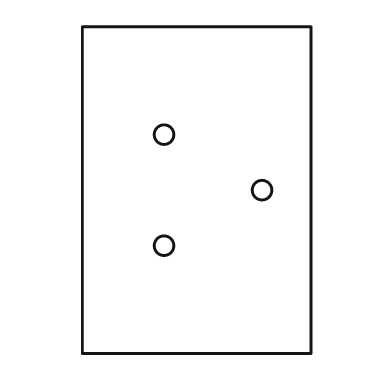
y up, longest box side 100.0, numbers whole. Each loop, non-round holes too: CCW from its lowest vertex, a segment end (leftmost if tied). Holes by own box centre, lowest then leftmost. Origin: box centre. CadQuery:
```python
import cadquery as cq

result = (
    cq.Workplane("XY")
    .moveTo(-35.0, -50.0)
    .lineTo(35.0, -50.0)
    .lineTo(35.0, 50.0)
    .lineTo(-35.0, 50.0)
    .close()
    .moveTo(-10.0, -17.0)
    .circle(3.0)
    .moveTo(20.0, 0.0)
    .circle(3.0)
    .moveTo(-10.0, 17.0)
    .circle(3.0)
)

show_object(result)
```